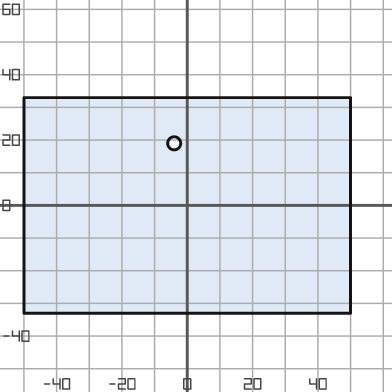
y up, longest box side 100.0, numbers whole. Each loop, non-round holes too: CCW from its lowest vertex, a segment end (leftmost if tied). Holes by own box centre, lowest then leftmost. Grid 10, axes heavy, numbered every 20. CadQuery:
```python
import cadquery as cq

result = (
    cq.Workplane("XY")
    .moveTo(-50.0, -33.0)
    .lineTo(50.0, -33.0)
    .lineTo(50.0, 33.0)
    .lineTo(-50.0, 33.0)
    .close()
    .moveTo(-4.0, 19.0)
    .circle(2.0)
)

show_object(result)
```